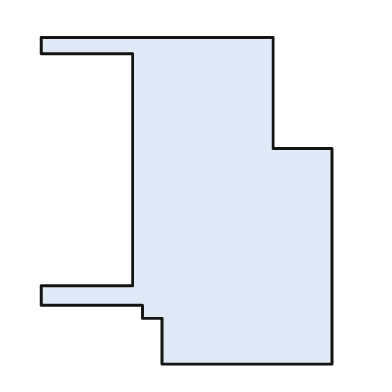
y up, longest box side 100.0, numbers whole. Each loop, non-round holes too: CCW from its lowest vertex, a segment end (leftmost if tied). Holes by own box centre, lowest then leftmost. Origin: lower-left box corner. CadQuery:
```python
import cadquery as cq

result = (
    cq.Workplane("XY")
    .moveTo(37.0, 0.0)
    .lineTo(89.0, 0.0)
    .lineTo(89.0, 66.0)
    .lineTo(71.0, 66.0)
    .lineTo(71.0, 100.0)
    .lineTo(0.0, 100.0)
    .lineTo(0.0, 95.0)
    .lineTo(28.0, 95.0)
    .lineTo(28.0, 24.0)
    .lineTo(0.0, 24.0)
    .lineTo(0.0, 18.0)
    .lineTo(31.0, 18.0)
    .lineTo(31.0, 14.0)
    .lineTo(37.0, 14.0)
    .close()
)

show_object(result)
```